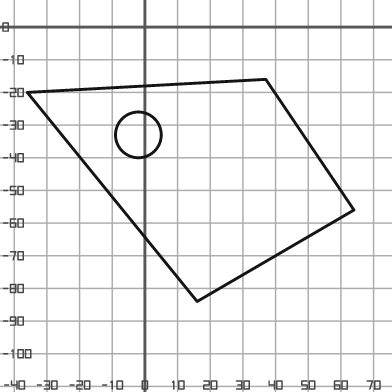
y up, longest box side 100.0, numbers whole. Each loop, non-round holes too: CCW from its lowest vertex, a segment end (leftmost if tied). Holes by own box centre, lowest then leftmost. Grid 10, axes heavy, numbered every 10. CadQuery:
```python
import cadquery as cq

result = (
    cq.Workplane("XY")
    .moveTo(16.0, -84.0)
    .lineTo(64.0, -56.0)
    .lineTo(37.0, -16.0)
    .lineTo(-36.0, -20.0)
    .close()
    .moveTo(-2.0, -33.0)
    .circle(7.0)
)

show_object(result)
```